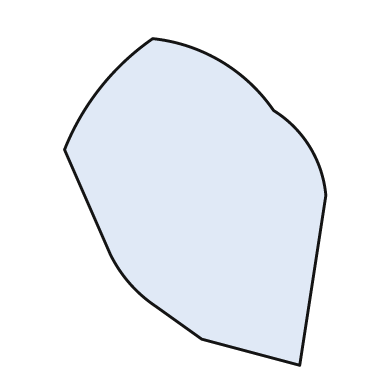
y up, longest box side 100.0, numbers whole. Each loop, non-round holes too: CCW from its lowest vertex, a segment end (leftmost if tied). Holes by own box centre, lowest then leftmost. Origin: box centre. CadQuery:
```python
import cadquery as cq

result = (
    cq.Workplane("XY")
    .moveTo(32.0, -50.0)
    .lineTo(40.0, 2.0)
    .threePointArc((35.0, 17.0), (24.0, 28.0))
    .threePointArc((8.0, 43.0), (-13.0, 50.0))
    .threePointArc((-29.0, 35.0), (-40.0, 16.0))
    .lineTo(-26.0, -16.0)
    .threePointArc((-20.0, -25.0), (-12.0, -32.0))
    .lineTo(2.0, -42.0)
    .close()
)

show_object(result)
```